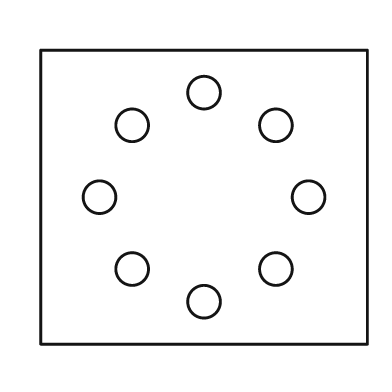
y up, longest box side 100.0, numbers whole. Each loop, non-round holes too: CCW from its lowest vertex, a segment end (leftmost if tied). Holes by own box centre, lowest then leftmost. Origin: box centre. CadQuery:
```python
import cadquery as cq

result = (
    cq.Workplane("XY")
    .moveTo(-50.0, -45.0)
    .lineTo(50.0, -45.0)
    .lineTo(50.0, 45.0)
    .lineTo(-50.0, 45.0)
    .close()
    .moveTo(0.0, -32.0)
    .circle(5.0)
    .moveTo(-22.0, -22.0)
    .circle(5.0)
    .moveTo(22.0, -22.0)
    .circle(5.0)
    .moveTo(-32.0, 0.0)
    .circle(5.0)
    .moveTo(32.0, 0.0)
    .circle(5.0)
    .moveTo(-22.0, 22.0)
    .circle(5.0)
    .moveTo(22.0, 22.0)
    .circle(5.0)
    .moveTo(0.0, 32.0)
    .circle(5.0)
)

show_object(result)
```